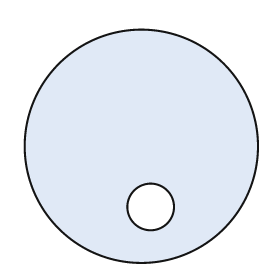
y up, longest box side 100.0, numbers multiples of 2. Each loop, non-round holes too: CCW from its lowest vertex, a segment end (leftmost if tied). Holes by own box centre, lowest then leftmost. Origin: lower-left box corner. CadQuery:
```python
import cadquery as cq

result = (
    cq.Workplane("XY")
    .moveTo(50.0, 50.0)
    .circle(50.0)
    .moveTo(54.0, 24.0)
    .circle(10.0)
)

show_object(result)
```